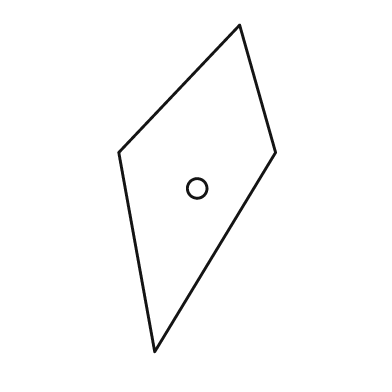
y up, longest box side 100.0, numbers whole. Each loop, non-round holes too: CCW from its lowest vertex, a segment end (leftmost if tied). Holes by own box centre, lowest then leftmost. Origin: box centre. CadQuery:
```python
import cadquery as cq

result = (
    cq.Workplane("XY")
    .moveTo(-13.0, -50.0)
    .lineTo(24.0, 11.0)
    .lineTo(13.0, 50.0)
    .lineTo(-24.0, 11.0)
    .close()
    .moveTo(0.0, 0.0)
    .circle(3.0)
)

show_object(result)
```